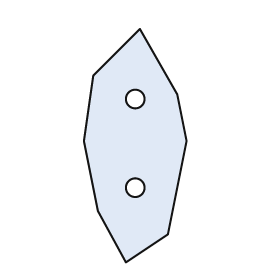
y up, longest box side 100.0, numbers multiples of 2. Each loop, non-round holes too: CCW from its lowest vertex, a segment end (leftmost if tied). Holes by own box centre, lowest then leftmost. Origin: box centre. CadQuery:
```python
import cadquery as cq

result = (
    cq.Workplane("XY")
    .moveTo(-4.0, -50.0)
    .lineTo(14.0, -38.0)
    .lineTo(22.0, 2.0)
    .lineTo(18.0, 22.0)
    .lineTo(2.0, 50.0)
    .lineTo(-18.0, 30.0)
    .lineTo(-22.0, 2.0)
    .lineTo(-16.0, -28.0)
    .close()
    .moveTo(0.0, -18.0)
    .circle(4.0)
    .moveTo(0.0, 20.0)
    .circle(4.0)
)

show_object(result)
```